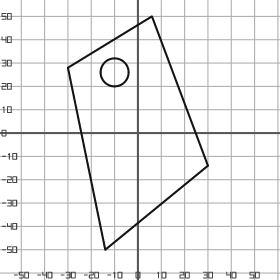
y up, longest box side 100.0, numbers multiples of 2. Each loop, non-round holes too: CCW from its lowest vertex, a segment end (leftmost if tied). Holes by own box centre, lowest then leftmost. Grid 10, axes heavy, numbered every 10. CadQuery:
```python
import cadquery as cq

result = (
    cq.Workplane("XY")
    .moveTo(-14.0, -50.0)
    .lineTo(30.0, -14.0)
    .lineTo(6.0, 50.0)
    .lineTo(-30.0, 28.0)
    .close()
    .moveTo(-10.0, 26.0)
    .circle(6.0)
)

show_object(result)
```